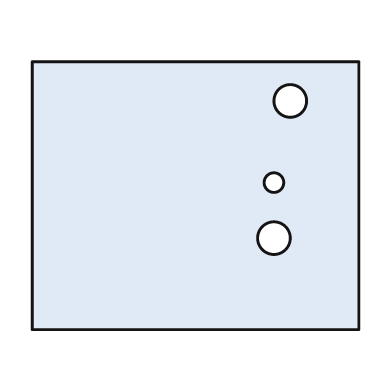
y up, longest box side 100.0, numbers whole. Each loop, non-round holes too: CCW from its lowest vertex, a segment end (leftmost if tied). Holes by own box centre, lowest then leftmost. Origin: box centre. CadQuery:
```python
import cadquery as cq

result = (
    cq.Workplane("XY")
    .moveTo(-50.0, -41.0)
    .lineTo(50.0, -41.0)
    .lineTo(50.0, 41.0)
    .lineTo(-50.0, 41.0)
    .close()
    .moveTo(24.0, -13.0)
    .circle(5.0)
    .moveTo(24.0, 4.0)
    .circle(3.0)
    .moveTo(29.0, 29.0)
    .circle(5.0)
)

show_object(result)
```